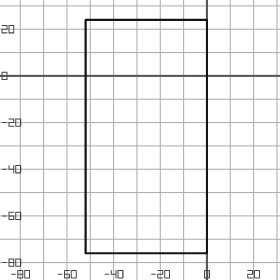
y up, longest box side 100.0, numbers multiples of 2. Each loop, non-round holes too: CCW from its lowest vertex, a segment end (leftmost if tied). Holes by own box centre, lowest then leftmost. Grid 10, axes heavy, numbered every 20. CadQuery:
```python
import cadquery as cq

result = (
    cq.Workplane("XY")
    .moveTo(-52.0, -76.0)
    .lineTo(0.0, -76.0)
    .lineTo(0.0, 24.0)
    .lineTo(-52.0, 24.0)
    .close()
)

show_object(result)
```